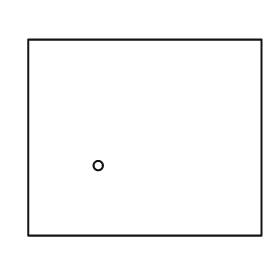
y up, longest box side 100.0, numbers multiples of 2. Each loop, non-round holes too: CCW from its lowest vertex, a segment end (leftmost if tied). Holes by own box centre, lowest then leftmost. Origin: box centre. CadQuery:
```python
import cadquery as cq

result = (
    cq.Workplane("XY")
    .moveTo(-50.0, -42.0)
    .lineTo(50.0, -42.0)
    .lineTo(50.0, 42.0)
    .lineTo(-50.0, 42.0)
    .close()
    .moveTo(-20.0, -12.0)
    .circle(2.0)
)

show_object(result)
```